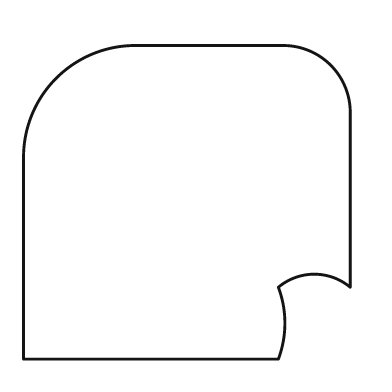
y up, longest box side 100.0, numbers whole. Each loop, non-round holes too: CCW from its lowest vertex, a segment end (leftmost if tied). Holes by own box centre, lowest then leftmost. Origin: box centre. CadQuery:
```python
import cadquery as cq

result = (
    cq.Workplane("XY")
    .moveTo(-50.0, -48.0)
    .lineTo(28.0, -48.0)
    .threePointArc((30.0, -37.0), (28.0, -26.0))
    .threePointArc((39.0, -22.0), (50.0, -26.0))
    .lineTo(50.0, 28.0)
    .threePointArc((44.0, 42.0), (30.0, 48.0))
    .lineTo(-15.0, 48.0)
    .threePointArc((-40.0, 38.0), (-50.0, 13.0))
    .close()
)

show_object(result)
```